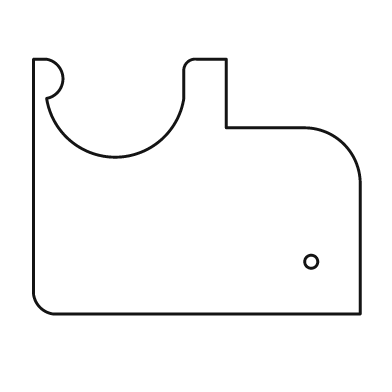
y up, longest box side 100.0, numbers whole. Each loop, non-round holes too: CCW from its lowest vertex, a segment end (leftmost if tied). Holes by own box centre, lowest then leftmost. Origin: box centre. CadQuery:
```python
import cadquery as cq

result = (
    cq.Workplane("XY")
    .moveTo(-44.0, -39.0)
    .lineTo(50.0, -39.0)
    .lineTo(50.0, 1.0)
    .threePointArc((45.0, 13.0), (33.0, 18.0))
    .lineTo(9.0, 18.0)
    .lineTo(9.0, 39.0)
    .lineTo(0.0, 39.0)
    .threePointArc((-3.0, 38.0), (-4.0, 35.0))
    .lineTo(-4.0, 27.0)
    .threePointArc((-25.0, 9.0), (-46.0, 27.0))
    .threePointArc((-41.0, 33.0), (-46.0, 39.0))
    .lineTo(-50.0, 39.0)
    .lineTo(-50.0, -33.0)
    .threePointArc((-48.0, -37.0), (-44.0, -39.0))
    .close()
    .moveTo(35.0, -23.0)
    .circle(2.0)
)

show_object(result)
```